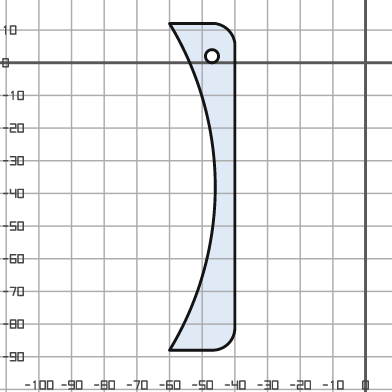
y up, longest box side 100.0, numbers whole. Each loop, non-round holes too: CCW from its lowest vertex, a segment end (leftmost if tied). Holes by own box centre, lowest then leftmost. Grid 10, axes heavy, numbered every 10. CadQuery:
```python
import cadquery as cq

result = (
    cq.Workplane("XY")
    .moveTo(-60.0, -88.0)
    .lineTo(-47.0, -88.0)
    .threePointArc((-42.0, -86.0), (-40.0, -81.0))
    .lineTo(-40.0, 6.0)
    .threePointArc((-42.0, 10.0), (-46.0, 12.0))
    .lineTo(-60.0, 12.0)
    .threePointArc((-46.0, -38.0), (-60.0, -88.0))
    .close()
    .moveTo(-47.0, 2.0)
    .circle(2.0)
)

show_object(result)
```